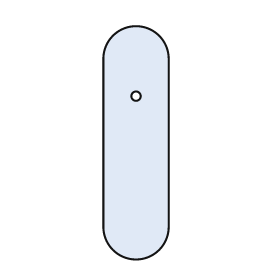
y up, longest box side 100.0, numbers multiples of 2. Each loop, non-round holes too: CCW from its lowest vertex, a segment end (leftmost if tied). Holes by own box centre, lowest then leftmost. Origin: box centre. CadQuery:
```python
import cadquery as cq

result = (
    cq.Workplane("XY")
    .moveTo(-14.0, -36.0)
    .threePointArc((0.0, -50.0), (14.0, -36.0))
    .lineTo(14.0, 36.0)
    .threePointArc((0.0, 50.0), (-14.0, 36.0))
    .close()
    .moveTo(0.0, 20.0)
    .circle(2.0)
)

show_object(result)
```